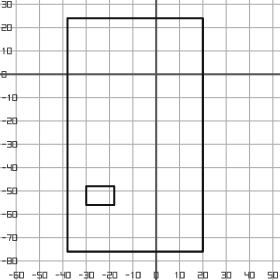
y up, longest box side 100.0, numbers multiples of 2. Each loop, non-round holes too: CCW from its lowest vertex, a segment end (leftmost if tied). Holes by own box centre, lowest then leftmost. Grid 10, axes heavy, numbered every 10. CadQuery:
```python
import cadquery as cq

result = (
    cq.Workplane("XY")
    .moveTo(-38.0, -76.0)
    .lineTo(20.0, -76.0)
    .lineTo(20.0, 24.0)
    .lineTo(-38.0, 24.0)
    .close()
    .moveTo(-30.0, -56.0)
    .lineTo(-18.0, -56.0)
    .lineTo(-18.0, -48.0)
    .lineTo(-30.0, -48.0)
    .close()
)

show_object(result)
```